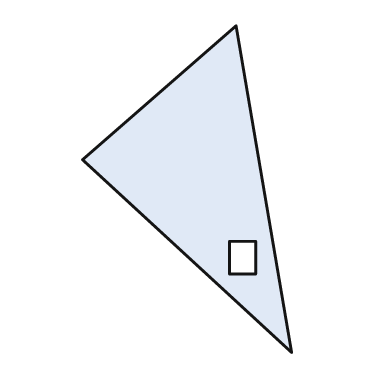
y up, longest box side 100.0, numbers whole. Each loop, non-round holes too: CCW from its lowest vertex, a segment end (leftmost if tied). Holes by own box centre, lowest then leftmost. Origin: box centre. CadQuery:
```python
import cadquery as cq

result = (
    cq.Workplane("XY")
    .moveTo(32.0, -50.0)
    .lineTo(15.0, 50.0)
    .lineTo(-32.0, 9.0)
    .close()
    .moveTo(13.0, -26.0)
    .lineTo(21.0, -26.0)
    .lineTo(21.0, -16.0)
    .lineTo(13.0, -16.0)
    .close()
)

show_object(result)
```